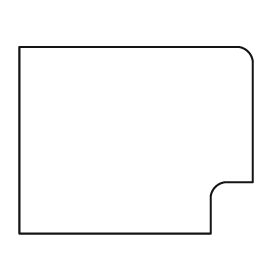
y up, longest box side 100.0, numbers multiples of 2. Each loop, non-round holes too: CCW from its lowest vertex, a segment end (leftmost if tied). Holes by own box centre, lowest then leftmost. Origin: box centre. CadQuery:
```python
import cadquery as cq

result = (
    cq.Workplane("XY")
    .moveTo(-50.0, -40.0)
    .lineTo(32.0, -40.0)
    .lineTo(32.0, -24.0)
    .threePointArc((34.0, -20.0), (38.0, -18.0))
    .lineTo(50.0, -18.0)
    .lineTo(50.0, 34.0)
    .threePointArc((48.0, 38.0), (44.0, 40.0))
    .lineTo(-50.0, 40.0)
    .close()
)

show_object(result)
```